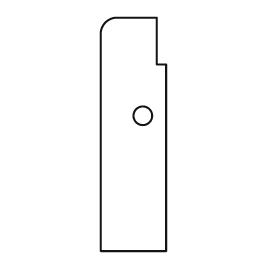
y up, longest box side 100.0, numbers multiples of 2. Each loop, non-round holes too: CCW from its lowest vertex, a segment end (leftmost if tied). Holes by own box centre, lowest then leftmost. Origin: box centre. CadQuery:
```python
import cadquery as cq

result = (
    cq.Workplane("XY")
    .moveTo(-14.0, -50.0)
    .lineTo(14.0, -50.0)
    .lineTo(14.0, 30.0)
    .lineTo(10.0, 30.0)
    .lineTo(10.0, 50.0)
    .lineTo(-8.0, 50.0)
    .threePointArc((-12.0, 48.0), (-14.0, 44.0))
    .close()
    .moveTo(4.0, 8.0)
    .circle(4.0)
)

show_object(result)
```